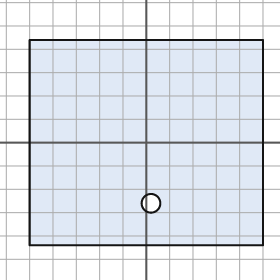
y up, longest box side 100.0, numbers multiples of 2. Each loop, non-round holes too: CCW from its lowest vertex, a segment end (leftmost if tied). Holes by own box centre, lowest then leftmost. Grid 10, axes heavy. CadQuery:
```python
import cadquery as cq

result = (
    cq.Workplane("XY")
    .moveTo(-50.0, -44.0)
    .lineTo(50.0, -44.0)
    .lineTo(50.0, 44.0)
    .lineTo(-50.0, 44.0)
    .close()
    .moveTo(2.0, -26.0)
    .circle(4.0)
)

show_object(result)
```